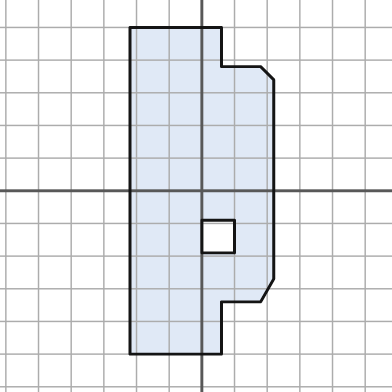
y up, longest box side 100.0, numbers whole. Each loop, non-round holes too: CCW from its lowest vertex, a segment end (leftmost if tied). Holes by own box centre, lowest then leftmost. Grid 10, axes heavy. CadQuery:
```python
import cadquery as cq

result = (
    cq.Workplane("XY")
    .moveTo(-22.0, -50.0)
    .lineTo(6.0, -50.0)
    .lineTo(6.0, -34.0)
    .lineTo(18.0, -34.0)
    .lineTo(22.0, -27.0)
    .lineTo(22.0, 34.0)
    .lineTo(18.0, 38.0)
    .lineTo(6.0, 38.0)
    .lineTo(6.0, 50.0)
    .lineTo(-22.0, 50.0)
    .close()
    .moveTo(0.0, -19.0)
    .lineTo(10.0, -19.0)
    .lineTo(10.0, -9.0)
    .lineTo(0.0, -9.0)
    .close()
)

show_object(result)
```